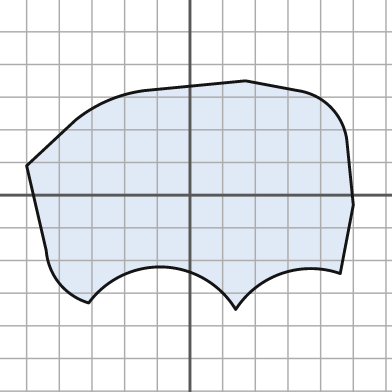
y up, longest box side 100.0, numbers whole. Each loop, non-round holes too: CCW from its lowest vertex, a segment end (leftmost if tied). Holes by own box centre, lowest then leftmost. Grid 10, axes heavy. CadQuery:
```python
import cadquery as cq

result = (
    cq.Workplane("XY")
    .moveTo(14.0, -35.0)
    .threePointArc((28.0, -24.0), (46.0, -24.0))
    .lineTo(50.0, -3.0)
    .lineTo(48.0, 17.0)
    .threePointArc((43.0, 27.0), (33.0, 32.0))
    .lineTo(17.0, 35.0)
    .lineTo(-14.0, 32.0)
    .threePointArc((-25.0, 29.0), (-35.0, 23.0))
    .lineTo(-50.0, 9.0)
    .lineTo(-44.0, -17.0)
    .threePointArc((-40.0, -27.0), (-31.0, -33.0))
    .threePointArc((-8.0, -22.0), (14.0, -35.0))
    .close()
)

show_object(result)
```